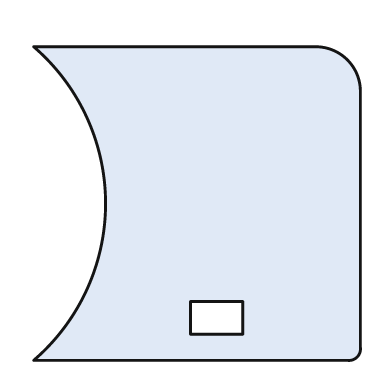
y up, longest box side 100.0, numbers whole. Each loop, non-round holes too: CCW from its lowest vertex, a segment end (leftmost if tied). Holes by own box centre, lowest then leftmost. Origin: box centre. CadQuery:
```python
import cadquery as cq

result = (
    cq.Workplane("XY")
    .moveTo(-50.0, -48.0)
    .lineTo(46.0, -48.0)
    .threePointArc((49.0, -47.0), (50.0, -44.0))
    .lineTo(50.0, 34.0)
    .threePointArc((46.0, 44.0), (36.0, 48.0))
    .lineTo(-50.0, 48.0)
    .threePointArc((-28.0, 0.0), (-50.0, -48.0))
    .close()
    .moveTo(-2.0, -40.0)
    .lineTo(14.0, -40.0)
    .lineTo(14.0, -30.0)
    .lineTo(-2.0, -30.0)
    .close()
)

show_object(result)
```